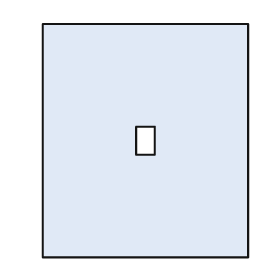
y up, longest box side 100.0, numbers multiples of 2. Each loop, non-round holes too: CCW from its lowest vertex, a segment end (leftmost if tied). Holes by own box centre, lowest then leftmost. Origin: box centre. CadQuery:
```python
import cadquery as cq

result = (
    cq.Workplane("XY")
    .moveTo(-44.0, -50.0)
    .lineTo(44.0, -50.0)
    .lineTo(44.0, 50.0)
    .lineTo(-44.0, 50.0)
    .close()
    .moveTo(-4.0, -6.0)
    .lineTo(4.0, -6.0)
    .lineTo(4.0, 6.0)
    .lineTo(-4.0, 6.0)
    .close()
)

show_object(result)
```